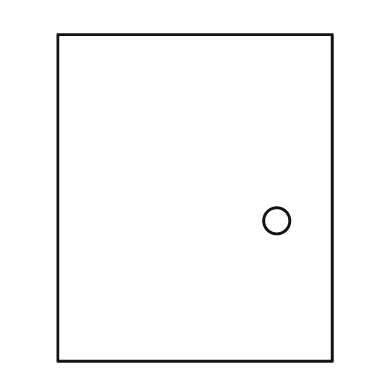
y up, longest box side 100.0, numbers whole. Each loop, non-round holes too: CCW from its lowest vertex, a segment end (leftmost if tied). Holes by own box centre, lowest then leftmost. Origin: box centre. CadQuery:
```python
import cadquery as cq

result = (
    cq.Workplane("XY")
    .moveTo(-42.0, -50.0)
    .lineTo(42.0, -50.0)
    .lineTo(42.0, 50.0)
    .lineTo(-42.0, 50.0)
    .close()
    .moveTo(25.0, -7.0)
    .circle(4.0)
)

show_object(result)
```